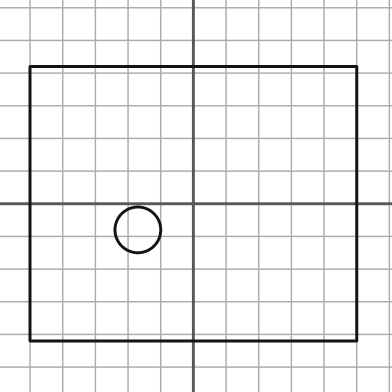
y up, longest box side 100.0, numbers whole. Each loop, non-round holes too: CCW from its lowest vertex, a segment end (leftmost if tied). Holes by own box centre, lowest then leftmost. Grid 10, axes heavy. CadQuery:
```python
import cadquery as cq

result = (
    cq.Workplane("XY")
    .moveTo(-50.0, -42.0)
    .lineTo(50.0, -42.0)
    .lineTo(50.0, 42.0)
    .lineTo(-50.0, 42.0)
    .close()
    .moveTo(-17.0, -8.0)
    .circle(7.0)
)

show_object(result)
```